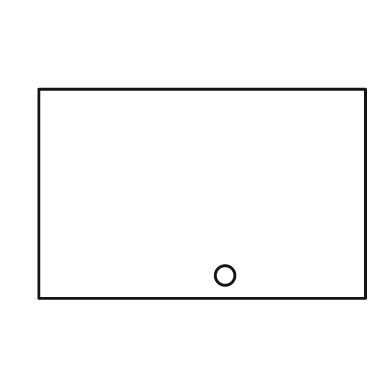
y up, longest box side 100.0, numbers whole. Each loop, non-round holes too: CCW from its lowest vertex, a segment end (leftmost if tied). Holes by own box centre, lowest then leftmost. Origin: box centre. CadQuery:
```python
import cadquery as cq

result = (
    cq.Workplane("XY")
    .moveTo(-50.0, -32.0)
    .lineTo(50.0, -32.0)
    .lineTo(50.0, 32.0)
    .lineTo(-50.0, 32.0)
    .close()
    .moveTo(7.0, -25.0)
    .circle(3.0)
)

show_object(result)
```